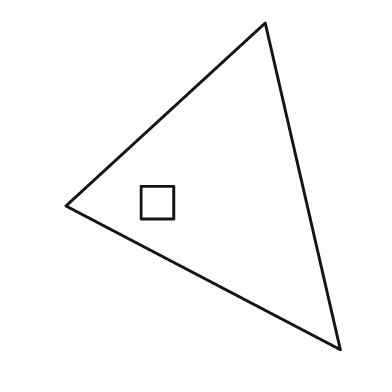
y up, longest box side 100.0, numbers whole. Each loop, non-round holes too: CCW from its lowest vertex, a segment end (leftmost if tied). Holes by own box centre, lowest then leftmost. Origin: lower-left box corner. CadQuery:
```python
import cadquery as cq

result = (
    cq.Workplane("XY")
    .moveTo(84.0, 0.0)
    .lineTo(61.0, 100.0)
    .lineTo(0.0, 44.0)
    .close()
    .moveTo(23.0, 40.0)
    .lineTo(33.0, 40.0)
    .lineTo(33.0, 50.0)
    .lineTo(23.0, 50.0)
    .close()
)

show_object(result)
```